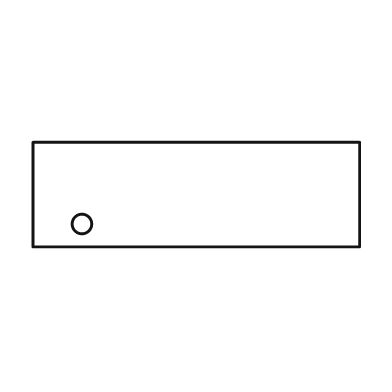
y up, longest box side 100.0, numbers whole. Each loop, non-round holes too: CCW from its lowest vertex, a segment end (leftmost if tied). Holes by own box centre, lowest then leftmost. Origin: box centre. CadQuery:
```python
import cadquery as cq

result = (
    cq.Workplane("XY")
    .moveTo(-50.0, -16.0)
    .lineTo(50.0, -16.0)
    .lineTo(50.0, 16.0)
    .lineTo(-50.0, 16.0)
    .close()
    .moveTo(-35.0, -9.0)
    .circle(3.0)
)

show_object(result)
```